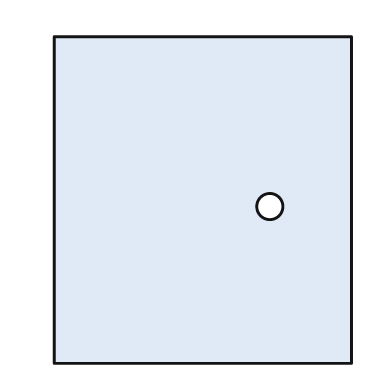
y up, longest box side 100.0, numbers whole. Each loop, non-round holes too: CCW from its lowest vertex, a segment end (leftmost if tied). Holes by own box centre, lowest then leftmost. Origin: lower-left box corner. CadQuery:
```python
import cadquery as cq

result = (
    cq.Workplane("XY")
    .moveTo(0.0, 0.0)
    .lineTo(91.0, 0.0)
    .lineTo(91.0, 100.0)
    .lineTo(0.0, 100.0)
    .close()
    .moveTo(66.0, 48.0)
    .circle(4.0)
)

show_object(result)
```